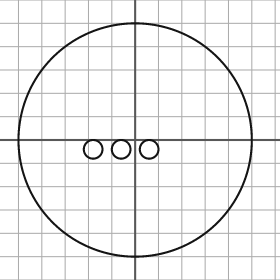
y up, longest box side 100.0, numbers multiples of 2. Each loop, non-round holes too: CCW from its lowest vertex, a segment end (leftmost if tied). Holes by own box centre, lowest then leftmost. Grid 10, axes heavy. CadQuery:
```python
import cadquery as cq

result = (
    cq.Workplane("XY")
    .moveTo(0.0, 0.0)
    .circle(50.0)
    .moveTo(-18.0, -4.0)
    .circle(4.0)
    .moveTo(-6.0, -4.0)
    .circle(4.0)
    .moveTo(6.0, -4.0)
    .circle(4.0)
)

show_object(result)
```